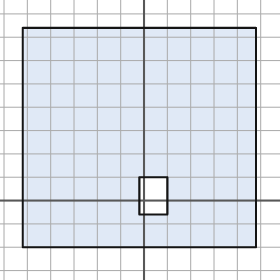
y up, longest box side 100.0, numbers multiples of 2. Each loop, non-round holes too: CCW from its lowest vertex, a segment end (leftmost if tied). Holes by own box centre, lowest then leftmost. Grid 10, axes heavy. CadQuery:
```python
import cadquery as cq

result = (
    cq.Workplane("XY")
    .moveTo(-52.0, -20.0)
    .lineTo(48.0, -20.0)
    .lineTo(48.0, 74.0)
    .lineTo(-52.0, 74.0)
    .close()
    .moveTo(-2.0, -6.0)
    .lineTo(10.0, -6.0)
    .lineTo(10.0, 10.0)
    .lineTo(-2.0, 10.0)
    .close()
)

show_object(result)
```